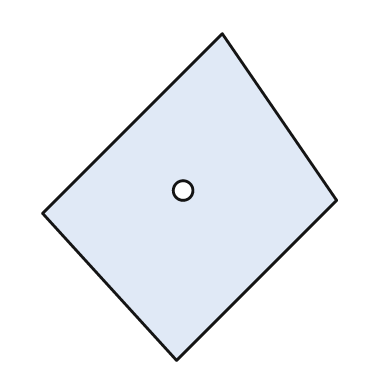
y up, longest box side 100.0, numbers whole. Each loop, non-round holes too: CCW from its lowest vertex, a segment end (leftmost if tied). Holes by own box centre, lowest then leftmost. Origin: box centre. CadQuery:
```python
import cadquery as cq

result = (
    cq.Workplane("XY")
    .moveTo(-4.0, -50.0)
    .lineTo(45.0, -1.0)
    .lineTo(10.0, 50.0)
    .lineTo(-45.0, -5.0)
    .close()
    .moveTo(-2.0, 2.0)
    .circle(3.0)
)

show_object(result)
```